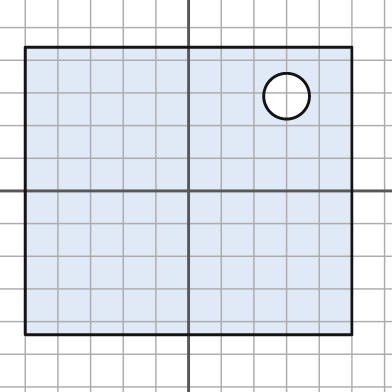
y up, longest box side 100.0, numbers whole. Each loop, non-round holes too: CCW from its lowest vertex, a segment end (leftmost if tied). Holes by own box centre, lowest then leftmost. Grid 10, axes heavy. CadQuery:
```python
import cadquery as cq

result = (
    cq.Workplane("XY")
    .moveTo(-50.0, -44.0)
    .lineTo(50.0, -44.0)
    .lineTo(50.0, 44.0)
    .lineTo(-50.0, 44.0)
    .close()
    .moveTo(30.0, 29.0)
    .circle(7.0)
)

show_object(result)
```